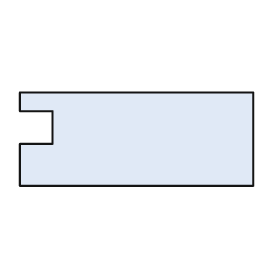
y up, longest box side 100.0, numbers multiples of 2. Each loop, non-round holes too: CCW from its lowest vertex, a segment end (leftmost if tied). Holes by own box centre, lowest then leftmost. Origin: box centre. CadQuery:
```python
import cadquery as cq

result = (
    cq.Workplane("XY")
    .moveTo(-50.0, -20.0)
    .lineTo(50.0, -20.0)
    .lineTo(50.0, 20.0)
    .lineTo(-50.0, 20.0)
    .lineTo(-50.0, 12.0)
    .lineTo(-36.0, 12.0)
    .lineTo(-36.0, -2.0)
    .lineTo(-50.0, -2.0)
    .close()
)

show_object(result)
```